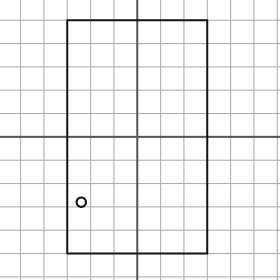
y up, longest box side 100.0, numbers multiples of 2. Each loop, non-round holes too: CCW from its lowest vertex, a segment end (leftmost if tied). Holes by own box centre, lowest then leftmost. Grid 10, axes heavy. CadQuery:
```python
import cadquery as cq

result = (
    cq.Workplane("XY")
    .moveTo(-30.0, -50.0)
    .lineTo(30.0, -50.0)
    .lineTo(30.0, 50.0)
    .lineTo(-30.0, 50.0)
    .close()
    .moveTo(-24.0, -28.0)
    .circle(2.0)
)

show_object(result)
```